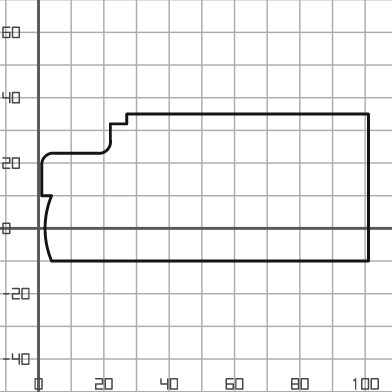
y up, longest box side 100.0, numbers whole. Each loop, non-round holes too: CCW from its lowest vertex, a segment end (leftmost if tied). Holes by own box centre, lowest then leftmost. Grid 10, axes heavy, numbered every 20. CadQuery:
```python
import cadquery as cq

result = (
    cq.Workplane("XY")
    .moveTo(4.0, -10.0)
    .lineTo(101.0, -10.0)
    .lineTo(101.0, 35.0)
    .lineTo(27.0, 35.0)
    .lineTo(27.0, 32.0)
    .lineTo(22.0, 32.0)
    .lineTo(22.0, 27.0)
    .threePointArc((21.0, 24.0), (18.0, 23.0))
    .lineTo(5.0, 23.0)
    .threePointArc((2.0, 22.0), (1.0, 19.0))
    .lineTo(1.0, 10.0)
    .lineTo(4.0, 10.0)
    .threePointArc((2.0, 0.0), (4.0, -10.0))
    .close()
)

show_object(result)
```